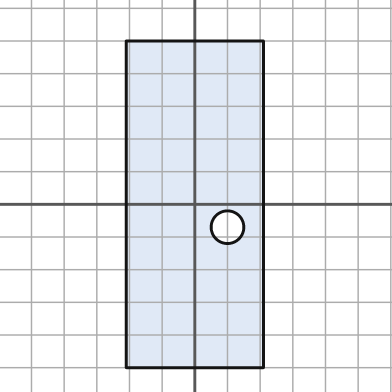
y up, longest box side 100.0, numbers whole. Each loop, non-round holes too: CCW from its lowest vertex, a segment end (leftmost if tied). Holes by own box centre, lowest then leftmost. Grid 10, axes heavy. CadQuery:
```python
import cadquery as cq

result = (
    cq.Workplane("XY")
    .moveTo(-21.0, -50.0)
    .lineTo(21.0, -50.0)
    .lineTo(21.0, 50.0)
    .lineTo(-21.0, 50.0)
    .close()
    .moveTo(10.0, -7.0)
    .circle(5.0)
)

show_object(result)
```